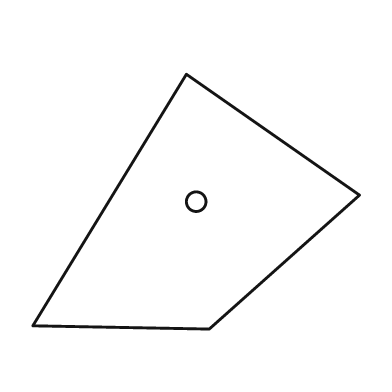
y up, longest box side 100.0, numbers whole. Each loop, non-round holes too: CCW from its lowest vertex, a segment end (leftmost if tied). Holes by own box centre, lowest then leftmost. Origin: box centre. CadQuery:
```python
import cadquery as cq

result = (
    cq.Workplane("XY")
    .moveTo(4.0, -39.0)
    .lineTo(50.0, 2.0)
    .lineTo(-3.0, 39.0)
    .lineTo(-50.0, -38.0)
    .close()
    .moveTo(0.0, 0.0)
    .circle(3.0)
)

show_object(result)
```